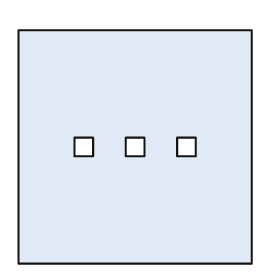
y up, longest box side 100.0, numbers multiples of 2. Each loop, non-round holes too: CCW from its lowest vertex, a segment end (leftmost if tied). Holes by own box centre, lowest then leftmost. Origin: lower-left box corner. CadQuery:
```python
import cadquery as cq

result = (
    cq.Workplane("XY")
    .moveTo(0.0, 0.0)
    .lineTo(100.0, 0.0)
    .lineTo(100.0, 100.0)
    .lineTo(0.0, 100.0)
    .close()
    .moveTo(24.0, 46.0)
    .lineTo(32.0, 46.0)
    .lineTo(32.0, 54.0)
    .lineTo(24.0, 54.0)
    .close()
    .moveTo(46.0, 46.0)
    .lineTo(54.0, 46.0)
    .lineTo(54.0, 54.0)
    .lineTo(46.0, 54.0)
    .close()
    .moveTo(68.0, 46.0)
    .lineTo(76.0, 46.0)
    .lineTo(76.0, 54.0)
    .lineTo(68.0, 54.0)
    .close()
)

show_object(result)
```